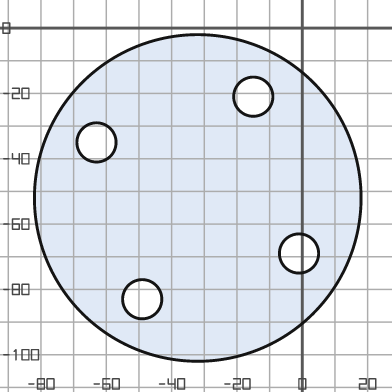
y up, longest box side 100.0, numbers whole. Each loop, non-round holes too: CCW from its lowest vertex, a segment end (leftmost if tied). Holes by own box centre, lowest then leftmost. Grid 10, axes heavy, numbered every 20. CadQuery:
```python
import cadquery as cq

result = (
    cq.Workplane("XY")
    .moveTo(-32.0, -52.0)
    .circle(50.0)
    .moveTo(-49.0, -83.0)
    .circle(6.0)
    .moveTo(-1.0, -69.0)
    .circle(6.0)
    .moveTo(-63.0, -35.0)
    .circle(6.0)
    .moveTo(-15.0, -21.0)
    .circle(6.0)
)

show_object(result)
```